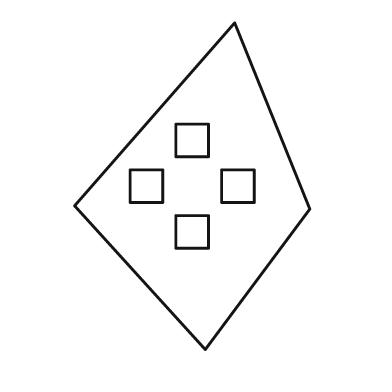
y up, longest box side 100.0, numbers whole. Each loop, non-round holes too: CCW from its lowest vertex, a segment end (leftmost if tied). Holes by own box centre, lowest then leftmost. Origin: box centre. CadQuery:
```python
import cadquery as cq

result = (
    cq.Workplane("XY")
    .moveTo(4.0, -50.0)
    .lineTo(36.0, -7.0)
    .lineTo(13.0, 50.0)
    .lineTo(-36.0, -6.0)
    .close()
    .moveTo(-5.0, -19.0)
    .lineTo(5.0, -19.0)
    .lineTo(5.0, -9.0)
    .lineTo(-5.0, -9.0)
    .close()
    .moveTo(-19.0, -5.0)
    .lineTo(-9.0, -5.0)
    .lineTo(-9.0, 5.0)
    .lineTo(-19.0, 5.0)
    .close()
    .moveTo(9.0, -5.0)
    .lineTo(19.0, -5.0)
    .lineTo(19.0, 5.0)
    .lineTo(9.0, 5.0)
    .close()
    .moveTo(-5.0, 9.0)
    .lineTo(5.0, 9.0)
    .lineTo(5.0, 19.0)
    .lineTo(-5.0, 19.0)
    .close()
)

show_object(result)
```